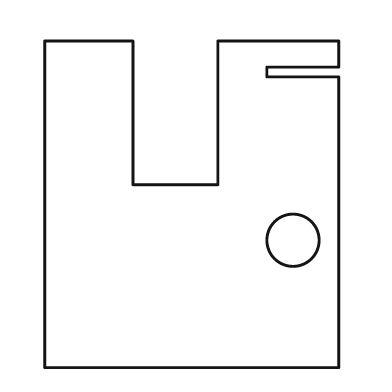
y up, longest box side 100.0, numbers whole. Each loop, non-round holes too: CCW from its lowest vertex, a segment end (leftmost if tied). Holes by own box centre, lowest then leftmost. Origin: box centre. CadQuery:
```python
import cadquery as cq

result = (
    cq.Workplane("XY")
    .moveTo(-45.0, -50.0)
    .lineTo(45.0, -50.0)
    .lineTo(45.0, 39.0)
    .lineTo(23.0, 39.0)
    .lineTo(23.0, 42.0)
    .lineTo(45.0, 42.0)
    .lineTo(45.0, 50.0)
    .lineTo(8.0, 50.0)
    .lineTo(8.0, 6.0)
    .lineTo(-18.0, 6.0)
    .lineTo(-18.0, 50.0)
    .lineTo(-45.0, 50.0)
    .close()
    .moveTo(31.0, -11.0)
    .circle(8.0)
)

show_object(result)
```